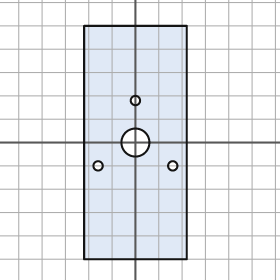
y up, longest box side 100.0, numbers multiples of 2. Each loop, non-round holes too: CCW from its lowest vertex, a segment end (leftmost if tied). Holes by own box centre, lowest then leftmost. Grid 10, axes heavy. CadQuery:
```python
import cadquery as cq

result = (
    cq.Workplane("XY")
    .moveTo(-22.0, -50.0)
    .lineTo(22.0, -50.0)
    .lineTo(22.0, 50.0)
    .lineTo(-22.0, 50.0)
    .close()
    .moveTo(-16.0, -10.0)
    .circle(2.0)
    .moveTo(16.0, -10.0)
    .circle(2.0)
    .moveTo(0.0, 0.0)
    .circle(6.0)
    .moveTo(0.0, 18.0)
    .circle(2.0)
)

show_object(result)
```